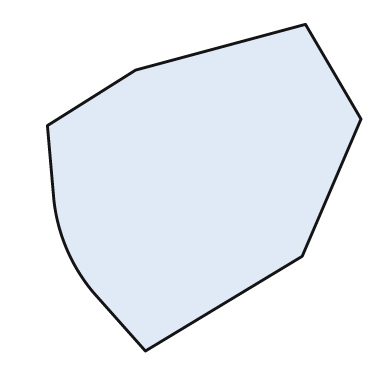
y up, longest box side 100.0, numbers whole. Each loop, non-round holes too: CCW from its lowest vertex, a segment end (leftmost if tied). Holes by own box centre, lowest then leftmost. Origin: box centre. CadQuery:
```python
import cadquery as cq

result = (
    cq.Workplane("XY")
    .moveTo(-18.0, -50.0)
    .lineTo(30.0, -21.0)
    .lineTo(48.0, 21.0)
    .lineTo(31.0, 50.0)
    .lineTo(-21.0, 36.0)
    .lineTo(-48.0, 19.0)
    .lineTo(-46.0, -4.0)
    .threePointArc((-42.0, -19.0), (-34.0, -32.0))
    .close()
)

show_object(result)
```